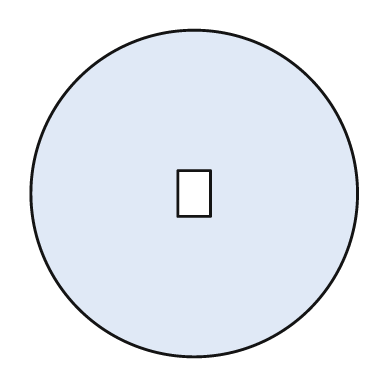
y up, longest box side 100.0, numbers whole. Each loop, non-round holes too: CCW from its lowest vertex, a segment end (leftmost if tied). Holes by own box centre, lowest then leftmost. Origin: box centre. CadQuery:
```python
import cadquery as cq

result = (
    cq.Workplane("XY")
    .moveTo(0.0, 0.0)
    .circle(50.0)
    .moveTo(-5.0, -7.0)
    .lineTo(5.0, -7.0)
    .lineTo(5.0, 7.0)
    .lineTo(-5.0, 7.0)
    .close()
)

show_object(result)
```